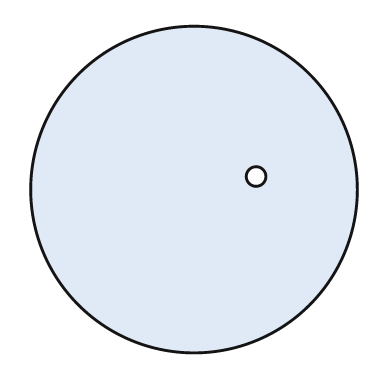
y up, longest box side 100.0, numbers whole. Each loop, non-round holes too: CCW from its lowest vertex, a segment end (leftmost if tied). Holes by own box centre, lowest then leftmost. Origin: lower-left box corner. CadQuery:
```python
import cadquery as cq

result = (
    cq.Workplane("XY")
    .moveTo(50.0, 50.0)
    .circle(50.0)
    .moveTo(69.0, 54.0)
    .circle(3.0)
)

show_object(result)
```